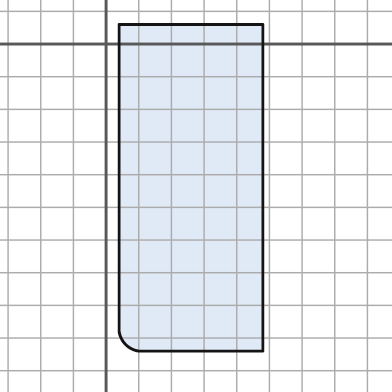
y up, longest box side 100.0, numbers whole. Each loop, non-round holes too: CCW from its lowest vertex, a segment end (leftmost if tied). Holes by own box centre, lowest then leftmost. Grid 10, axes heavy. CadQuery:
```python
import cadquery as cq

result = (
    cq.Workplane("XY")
    .moveTo(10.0, -94.0)
    .lineTo(48.0, -94.0)
    .lineTo(48.0, 6.0)
    .lineTo(4.0, 6.0)
    .lineTo(4.0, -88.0)
    .threePointArc((6.0, -92.0), (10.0, -94.0))
    .close()
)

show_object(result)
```